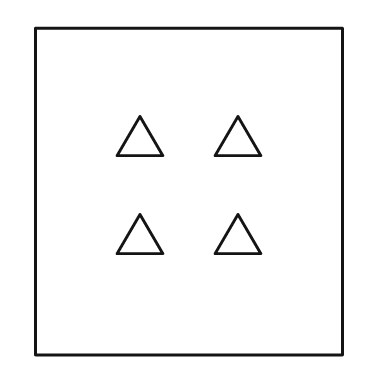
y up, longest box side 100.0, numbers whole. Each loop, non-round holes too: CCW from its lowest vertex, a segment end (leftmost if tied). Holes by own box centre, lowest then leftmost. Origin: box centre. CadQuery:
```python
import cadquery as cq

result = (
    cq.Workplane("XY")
    .moveTo(-47.0, -50.0)
    .lineTo(47.0, -50.0)
    .lineTo(47.0, 50.0)
    .lineTo(-47.0, 50.0)
    .close()
    .moveTo(-22.0, -19.0)
    .lineTo(-8.0, -19.0)
    .lineTo(-15.0, -7.0)
    .close()
    .moveTo(8.0, -19.0)
    .lineTo(22.0, -19.0)
    .lineTo(15.0, -7.0)
    .close()
    .moveTo(-22.0, 11.0)
    .lineTo(-8.0, 11.0)
    .lineTo(-15.0, 23.0)
    .close()
    .moveTo(8.0, 11.0)
    .lineTo(22.0, 11.0)
    .lineTo(15.0, 23.0)
    .close()
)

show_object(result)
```